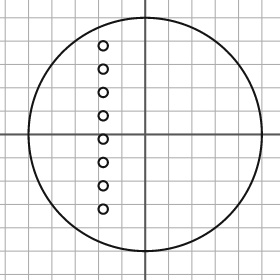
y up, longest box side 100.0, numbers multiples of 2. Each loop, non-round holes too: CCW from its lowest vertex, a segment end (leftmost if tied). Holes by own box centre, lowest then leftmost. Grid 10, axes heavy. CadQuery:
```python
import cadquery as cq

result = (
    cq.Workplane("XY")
    .moveTo(0.0, 0.0)
    .circle(50.0)
    .moveTo(-18.0, -32.0)
    .circle(2.0)
    .moveTo(-18.0, -22.0)
    .circle(2.0)
    .moveTo(-18.0, -12.0)
    .circle(2.0)
    .moveTo(-18.0, -2.0)
    .circle(2.0)
    .moveTo(-18.0, 8.0)
    .circle(2.0)
    .moveTo(-18.0, 18.0)
    .circle(2.0)
    .moveTo(-18.0, 28.0)
    .circle(2.0)
    .moveTo(-18.0, 38.0)
    .circle(2.0)
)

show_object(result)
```